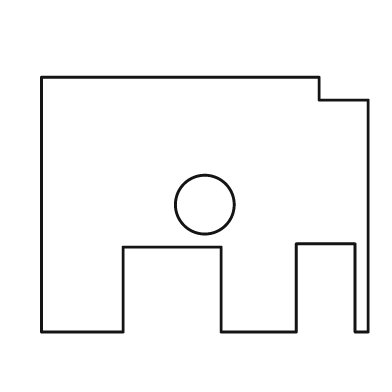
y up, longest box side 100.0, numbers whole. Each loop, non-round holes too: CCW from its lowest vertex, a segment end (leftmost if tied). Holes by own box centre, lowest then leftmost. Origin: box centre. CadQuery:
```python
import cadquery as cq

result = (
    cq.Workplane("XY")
    .moveTo(-50.0, -39.0)
    .lineTo(-25.0, -39.0)
    .lineTo(-25.0, -13.0)
    .lineTo(5.0, -13.0)
    .lineTo(5.0, -39.0)
    .lineTo(28.0, -39.0)
    .lineTo(28.0, -12.0)
    .lineTo(46.0, -12.0)
    .lineTo(46.0, -39.0)
    .lineTo(50.0, -39.0)
    .lineTo(50.0, 32.0)
    .lineTo(35.0, 32.0)
    .lineTo(35.0, 39.0)
    .lineTo(-50.0, 39.0)
    .close()
    .moveTo(0.0, 0.0)
    .circle(9.0)
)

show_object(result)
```